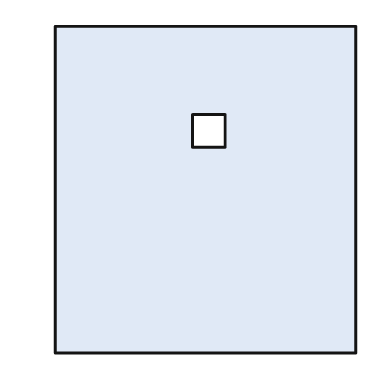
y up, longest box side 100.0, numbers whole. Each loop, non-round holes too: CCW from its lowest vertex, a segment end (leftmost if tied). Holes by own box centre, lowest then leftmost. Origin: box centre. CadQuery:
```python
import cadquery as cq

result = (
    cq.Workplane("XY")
    .moveTo(-46.0, -50.0)
    .lineTo(46.0, -50.0)
    .lineTo(46.0, 50.0)
    .lineTo(-46.0, 50.0)
    .close()
    .moveTo(-4.0, 13.0)
    .lineTo(6.0, 13.0)
    .lineTo(6.0, 23.0)
    .lineTo(-4.0, 23.0)
    .close()
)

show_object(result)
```